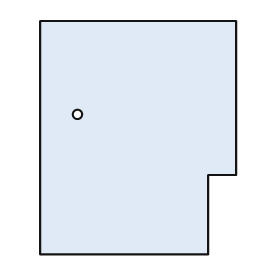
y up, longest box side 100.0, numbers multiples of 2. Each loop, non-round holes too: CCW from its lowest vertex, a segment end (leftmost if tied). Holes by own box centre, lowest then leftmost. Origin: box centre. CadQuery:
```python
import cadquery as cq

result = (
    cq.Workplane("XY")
    .moveTo(-42.0, -50.0)
    .lineTo(30.0, -50.0)
    .lineTo(30.0, -16.0)
    .lineTo(42.0, -16.0)
    .lineTo(42.0, 50.0)
    .lineTo(-42.0, 50.0)
    .close()
    .moveTo(-26.0, 10.0)
    .circle(2.0)
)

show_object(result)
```